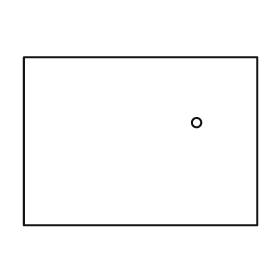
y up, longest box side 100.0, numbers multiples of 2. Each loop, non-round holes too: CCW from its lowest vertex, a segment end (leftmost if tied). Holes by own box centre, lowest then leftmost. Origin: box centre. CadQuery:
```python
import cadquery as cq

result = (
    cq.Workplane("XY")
    .moveTo(-50.0, -36.0)
    .lineTo(50.0, -36.0)
    .lineTo(50.0, 36.0)
    .lineTo(-50.0, 36.0)
    .close()
    .moveTo(24.0, 8.0)
    .circle(2.0)
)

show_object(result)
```